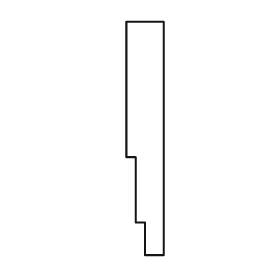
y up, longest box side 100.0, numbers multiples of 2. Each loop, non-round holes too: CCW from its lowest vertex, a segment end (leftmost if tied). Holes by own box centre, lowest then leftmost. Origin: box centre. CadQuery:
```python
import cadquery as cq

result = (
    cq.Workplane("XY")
    .moveTo(0.0, -50.0)
    .lineTo(8.0, -50.0)
    .lineTo(8.0, 50.0)
    .lineTo(-8.0, 50.0)
    .lineTo(-8.0, -8.0)
    .lineTo(-4.0, -8.0)
    .lineTo(-4.0, -36.0)
    .lineTo(0.0, -36.0)
    .close()
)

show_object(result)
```